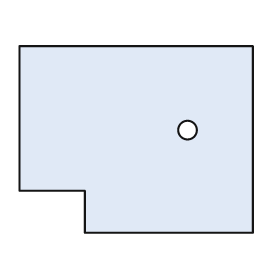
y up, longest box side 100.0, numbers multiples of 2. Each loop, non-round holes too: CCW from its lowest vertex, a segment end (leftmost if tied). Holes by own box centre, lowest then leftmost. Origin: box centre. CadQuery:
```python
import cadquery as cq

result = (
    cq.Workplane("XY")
    .moveTo(-22.0, -40.0)
    .lineTo(50.0, -40.0)
    .lineTo(50.0, 40.0)
    .lineTo(-50.0, 40.0)
    .lineTo(-50.0, -22.0)
    .lineTo(-22.0, -22.0)
    .close()
    .moveTo(22.0, 4.0)
    .circle(4.0)
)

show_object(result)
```